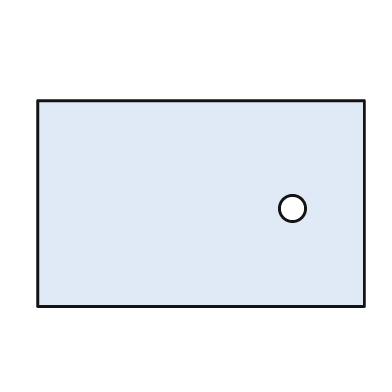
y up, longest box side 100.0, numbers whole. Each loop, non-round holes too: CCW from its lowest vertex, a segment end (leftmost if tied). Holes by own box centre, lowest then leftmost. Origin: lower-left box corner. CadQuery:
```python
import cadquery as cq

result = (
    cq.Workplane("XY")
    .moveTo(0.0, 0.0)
    .lineTo(100.0, 0.0)
    .lineTo(100.0, 63.0)
    .lineTo(0.0, 63.0)
    .close()
    .moveTo(78.0, 30.0)
    .circle(4.0)
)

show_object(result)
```